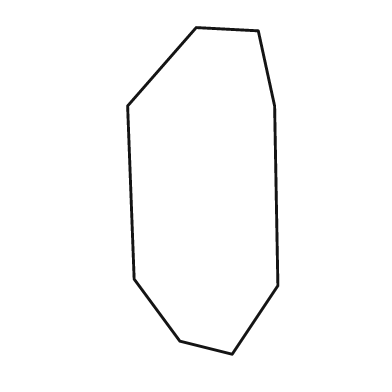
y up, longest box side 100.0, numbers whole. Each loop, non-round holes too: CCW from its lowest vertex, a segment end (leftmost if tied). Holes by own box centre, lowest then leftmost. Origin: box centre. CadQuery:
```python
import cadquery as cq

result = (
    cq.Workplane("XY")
    .moveTo(9.0, -50.0)
    .lineTo(23.0, -29.0)
    .lineTo(22.0, 26.0)
    .lineTo(17.0, 49.0)
    .lineTo(-2.0, 50.0)
    .lineTo(-23.0, 26.0)
    .lineTo(-21.0, -27.0)
    .lineTo(-7.0, -46.0)
    .close()
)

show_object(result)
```